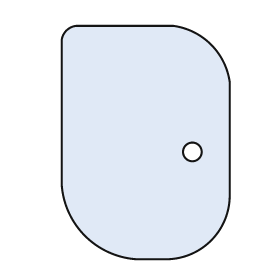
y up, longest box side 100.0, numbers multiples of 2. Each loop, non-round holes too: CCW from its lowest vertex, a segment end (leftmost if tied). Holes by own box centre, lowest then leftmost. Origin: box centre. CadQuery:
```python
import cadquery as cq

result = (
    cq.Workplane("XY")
    .moveTo(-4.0, -50.0)
    .lineTo(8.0, -50.0)
    .threePointArc((28.0, -42.0), (36.0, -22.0))
    .lineTo(36.0, 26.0)
    .threePointArc((28.0, 42.0), (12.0, 50.0))
    .lineTo(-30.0, 50.0)
    .threePointArc((-34.0, 48.0), (-36.0, 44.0))
    .lineTo(-36.0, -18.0)
    .threePointArc((-26.0, -40.0), (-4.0, -50.0))
    .close()
    .moveTo(20.0, -4.0)
    .circle(4.0)
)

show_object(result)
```